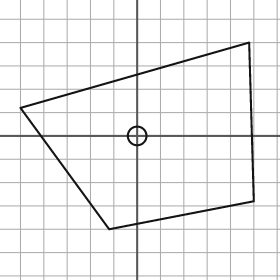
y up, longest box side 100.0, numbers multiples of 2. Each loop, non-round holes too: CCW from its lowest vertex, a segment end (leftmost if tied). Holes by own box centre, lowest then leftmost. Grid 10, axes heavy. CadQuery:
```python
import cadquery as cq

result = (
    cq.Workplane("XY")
    .moveTo(-12.0, -40.0)
    .lineTo(50.0, -28.0)
    .lineTo(48.0, 40.0)
    .lineTo(-50.0, 12.0)
    .close()
    .moveTo(0.0, 0.0)
    .circle(4.0)
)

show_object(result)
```